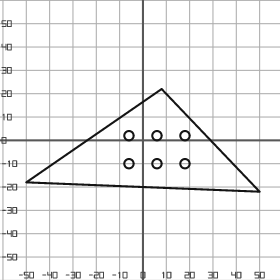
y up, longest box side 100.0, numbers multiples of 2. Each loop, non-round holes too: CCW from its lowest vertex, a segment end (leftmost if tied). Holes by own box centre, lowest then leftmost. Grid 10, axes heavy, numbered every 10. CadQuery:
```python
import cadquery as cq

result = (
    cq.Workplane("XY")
    .moveTo(50.0, -22.0)
    .lineTo(8.0, 22.0)
    .lineTo(-50.0, -18.0)
    .close()
    .moveTo(-6.0, -10.0)
    .circle(2.0)
    .moveTo(6.0, -10.0)
    .circle(2.0)
    .moveTo(18.0, -10.0)
    .circle(2.0)
    .moveTo(-6.0, 2.0)
    .circle(2.0)
    .moveTo(6.0, 2.0)
    .circle(2.0)
    .moveTo(18.0, 2.0)
    .circle(2.0)
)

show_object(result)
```